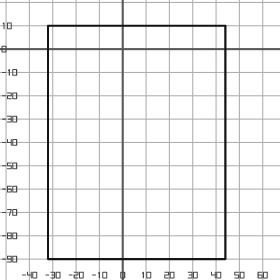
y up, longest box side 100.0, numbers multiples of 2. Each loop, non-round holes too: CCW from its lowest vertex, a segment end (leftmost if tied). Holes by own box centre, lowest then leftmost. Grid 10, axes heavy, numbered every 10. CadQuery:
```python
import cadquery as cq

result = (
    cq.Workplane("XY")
    .moveTo(-32.0, -90.0)
    .lineTo(44.0, -90.0)
    .lineTo(44.0, 10.0)
    .lineTo(-32.0, 10.0)
    .close()
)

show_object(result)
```